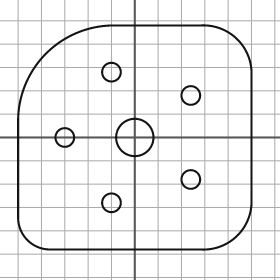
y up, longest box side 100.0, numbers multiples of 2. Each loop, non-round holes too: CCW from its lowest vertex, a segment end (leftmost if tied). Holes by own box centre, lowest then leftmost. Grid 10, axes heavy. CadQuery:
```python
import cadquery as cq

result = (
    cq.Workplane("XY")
    .moveTo(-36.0, -48.0)
    .lineTo(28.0, -48.0)
    .threePointArc((44.0, -42.0), (50.0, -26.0))
    .lineTo(50.0, 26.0)
    .threePointArc((44.0, 42.0), (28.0, 48.0))
    .lineTo(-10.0, 48.0)
    .threePointArc((-38.0, 36.0), (-50.0, 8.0))
    .lineTo(-50.0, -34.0)
    .threePointArc((-46.0, -44.0), (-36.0, -48.0))
    .close()
    .moveTo(-10.0, -28.0)
    .circle(4.0)
    .moveTo(24.0, -18.0)
    .circle(4.0)
    .moveTo(-30.0, 0.0)
    .circle(4.0)
    .moveTo(0.0, 0.0)
    .circle(8.0)
    .moveTo(24.0, 18.0)
    .circle(4.0)
    .moveTo(-10.0, 28.0)
    .circle(4.0)
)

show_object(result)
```